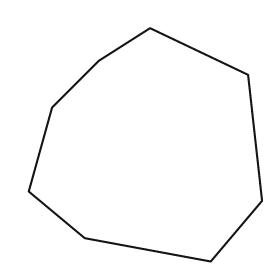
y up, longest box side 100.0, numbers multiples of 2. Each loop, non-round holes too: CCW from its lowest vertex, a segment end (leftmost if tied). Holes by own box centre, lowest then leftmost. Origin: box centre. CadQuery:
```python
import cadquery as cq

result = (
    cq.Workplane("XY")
    .moveTo(28.0, -50.0)
    .lineTo(50.0, -24.0)
    .lineTo(44.0, 30.0)
    .lineTo(2.0, 50.0)
    .lineTo(-20.0, 36.0)
    .lineTo(-40.0, 16.0)
    .lineTo(-50.0, -20.0)
    .lineTo(-26.0, -40.0)
    .close()
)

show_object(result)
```